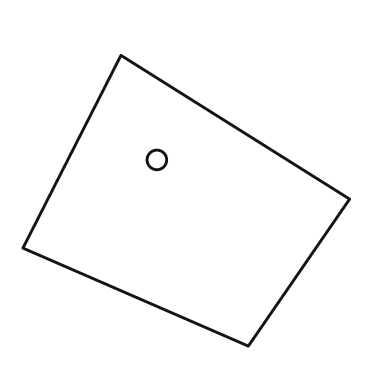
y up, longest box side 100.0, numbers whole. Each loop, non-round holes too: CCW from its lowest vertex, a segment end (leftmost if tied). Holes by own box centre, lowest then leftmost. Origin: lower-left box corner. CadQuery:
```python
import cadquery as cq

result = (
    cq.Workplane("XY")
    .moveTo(69.0, 0.0)
    .lineTo(100.0, 45.0)
    .lineTo(30.0, 89.0)
    .lineTo(0.0, 30.0)
    .close()
    .moveTo(41.0, 57.0)
    .circle(3.0)
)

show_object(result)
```